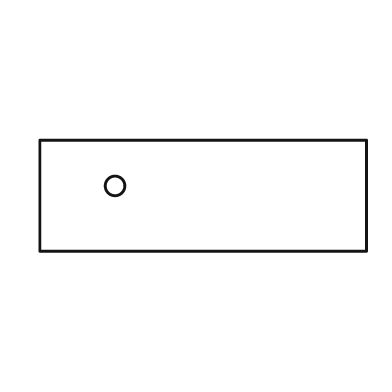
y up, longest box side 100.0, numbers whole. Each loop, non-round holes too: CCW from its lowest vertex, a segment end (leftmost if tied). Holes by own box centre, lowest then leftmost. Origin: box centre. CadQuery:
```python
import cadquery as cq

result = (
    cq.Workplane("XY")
    .moveTo(-50.0, -17.0)
    .lineTo(50.0, -17.0)
    .lineTo(50.0, 17.0)
    .lineTo(-50.0, 17.0)
    .close()
    .moveTo(-27.0, 3.0)
    .circle(3.0)
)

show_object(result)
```